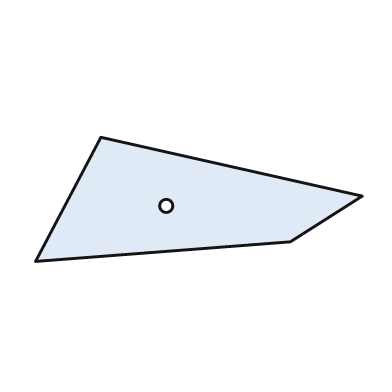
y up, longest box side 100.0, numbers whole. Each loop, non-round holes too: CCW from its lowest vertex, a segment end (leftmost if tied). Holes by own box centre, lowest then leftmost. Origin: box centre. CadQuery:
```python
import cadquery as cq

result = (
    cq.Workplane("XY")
    .moveTo(-50.0, -19.0)
    .lineTo(28.0, -13.0)
    .lineTo(50.0, 1.0)
    .lineTo(-30.0, 19.0)
    .close()
    .moveTo(-10.0, -2.0)
    .circle(2.0)
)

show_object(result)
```